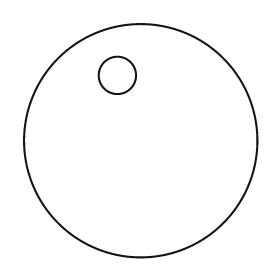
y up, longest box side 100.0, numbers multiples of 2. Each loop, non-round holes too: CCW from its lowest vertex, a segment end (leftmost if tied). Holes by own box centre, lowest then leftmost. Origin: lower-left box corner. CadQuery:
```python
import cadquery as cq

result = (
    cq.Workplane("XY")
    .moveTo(50.0, 50.0)
    .circle(50.0)
    .moveTo(40.0, 78.0)
    .circle(8.0)
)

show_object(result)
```